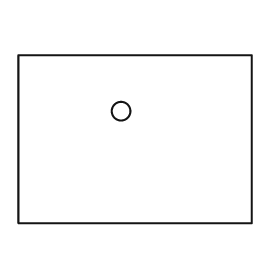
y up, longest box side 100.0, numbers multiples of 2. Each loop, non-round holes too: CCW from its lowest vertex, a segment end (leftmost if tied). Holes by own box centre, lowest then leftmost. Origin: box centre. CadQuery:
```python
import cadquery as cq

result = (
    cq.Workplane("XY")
    .moveTo(-50.0, -36.0)
    .lineTo(50.0, -36.0)
    .lineTo(50.0, 36.0)
    .lineTo(-50.0, 36.0)
    .close()
    .moveTo(-6.0, 12.0)
    .circle(4.0)
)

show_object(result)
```